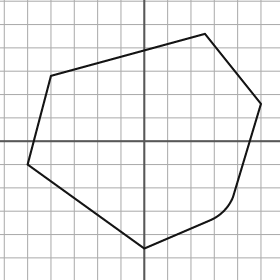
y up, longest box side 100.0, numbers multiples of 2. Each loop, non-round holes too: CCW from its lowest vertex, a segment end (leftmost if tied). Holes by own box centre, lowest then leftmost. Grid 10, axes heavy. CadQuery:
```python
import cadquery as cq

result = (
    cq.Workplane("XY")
    .moveTo(0.0, -46.0)
    .lineTo(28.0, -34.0)
    .threePointArc((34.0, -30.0), (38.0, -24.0))
    .lineTo(50.0, 16.0)
    .lineTo(26.0, 46.0)
    .lineTo(-40.0, 28.0)
    .lineTo(-50.0, -10.0)
    .close()
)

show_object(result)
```